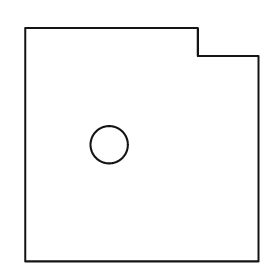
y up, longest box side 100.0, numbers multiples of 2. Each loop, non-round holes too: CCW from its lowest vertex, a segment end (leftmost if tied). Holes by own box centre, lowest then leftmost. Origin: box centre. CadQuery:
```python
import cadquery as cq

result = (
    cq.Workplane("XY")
    .moveTo(-50.0, -50.0)
    .lineTo(50.0, -50.0)
    .lineTo(50.0, 38.0)
    .lineTo(24.0, 38.0)
    .lineTo(24.0, 50.0)
    .lineTo(-50.0, 50.0)
    .close()
    .moveTo(-14.0, 0.0)
    .circle(8.0)
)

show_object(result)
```